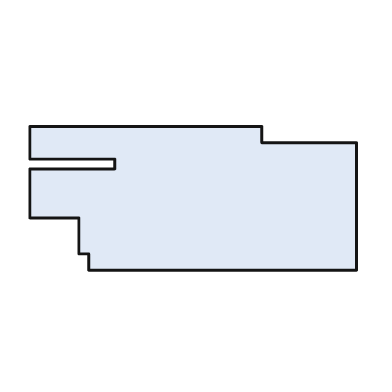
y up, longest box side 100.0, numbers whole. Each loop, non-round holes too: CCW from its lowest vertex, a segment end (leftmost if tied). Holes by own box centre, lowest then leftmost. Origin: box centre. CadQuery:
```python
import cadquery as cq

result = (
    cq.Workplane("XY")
    .moveTo(-32.0, -22.0)
    .lineTo(50.0, -22.0)
    .lineTo(50.0, 17.0)
    .lineTo(21.0, 17.0)
    .lineTo(21.0, 22.0)
    .lineTo(-50.0, 22.0)
    .lineTo(-50.0, 12.0)
    .lineTo(-24.0, 12.0)
    .lineTo(-24.0, 9.0)
    .lineTo(-50.0, 9.0)
    .lineTo(-50.0, -6.0)
    .lineTo(-35.0, -6.0)
    .lineTo(-35.0, -17.0)
    .lineTo(-32.0, -17.0)
    .close()
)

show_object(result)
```